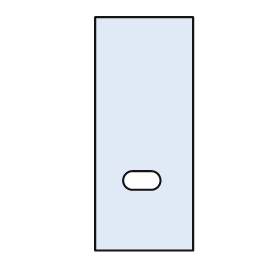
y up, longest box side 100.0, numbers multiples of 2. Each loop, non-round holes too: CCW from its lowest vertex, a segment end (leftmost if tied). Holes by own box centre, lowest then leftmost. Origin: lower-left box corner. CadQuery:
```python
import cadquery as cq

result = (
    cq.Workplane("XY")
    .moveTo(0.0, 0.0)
    .lineTo(42.0, 0.0)
    .lineTo(42.0, 100.0)
    .lineTo(0.0, 100.0)
    .close()
    .moveTo(16.0, 26.0)
    .lineTo(24.0, 26.0)
    .threePointArc((28.0, 30.0), (24.0, 34.0))
    .lineTo(16.0, 34.0)
    .threePointArc((12.0, 30.0), (16.0, 26.0))
    .close()
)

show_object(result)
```